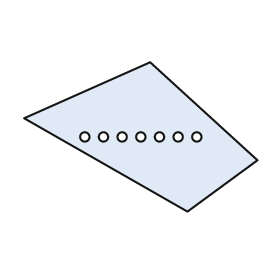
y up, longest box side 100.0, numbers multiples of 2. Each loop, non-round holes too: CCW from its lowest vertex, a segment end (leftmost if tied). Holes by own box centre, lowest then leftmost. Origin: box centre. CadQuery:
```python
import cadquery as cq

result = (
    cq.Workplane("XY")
    .moveTo(20.0, -32.0)
    .lineTo(50.0, -10.0)
    .lineTo(4.0, 32.0)
    .lineTo(-50.0, 8.0)
    .close()
    .moveTo(-24.0, 0.0)
    .circle(2.0)
    .moveTo(-16.0, 0.0)
    .circle(2.0)
    .moveTo(-8.0, 0.0)
    .circle(2.0)
    .moveTo(0.0, 0.0)
    .circle(2.0)
    .moveTo(8.0, 0.0)
    .circle(2.0)
    .moveTo(16.0, 0.0)
    .circle(2.0)
    .moveTo(24.0, 0.0)
    .circle(2.0)
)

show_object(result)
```